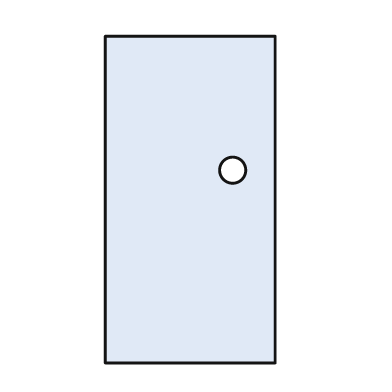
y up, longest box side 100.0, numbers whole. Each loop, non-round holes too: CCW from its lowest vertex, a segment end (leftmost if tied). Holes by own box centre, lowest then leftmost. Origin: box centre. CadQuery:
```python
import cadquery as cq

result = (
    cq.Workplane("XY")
    .moveTo(-26.0, -50.0)
    .lineTo(26.0, -50.0)
    .lineTo(26.0, 50.0)
    .lineTo(-26.0, 50.0)
    .close()
    .moveTo(13.0, 9.0)
    .circle(4.0)
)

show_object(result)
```